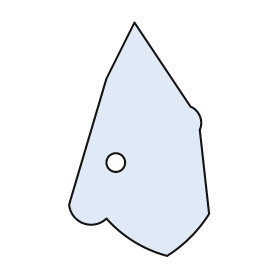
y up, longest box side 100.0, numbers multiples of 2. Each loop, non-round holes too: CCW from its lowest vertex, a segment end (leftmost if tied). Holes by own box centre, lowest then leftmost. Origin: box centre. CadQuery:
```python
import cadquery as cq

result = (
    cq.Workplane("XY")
    .moveTo(12.0, -50.0)
    .threePointArc((22.0, -42.0), (30.0, -32.0))
    .lineTo(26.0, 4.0)
    .threePointArc((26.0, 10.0), (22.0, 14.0))
    .lineTo(-2.0, 50.0)
    .lineTo(-14.0, 26.0)
    .lineTo(-30.0, -28.0)
    .threePointArc((-24.0, -36.0), (-14.0, -34.0))
    .threePointArc((-2.0, -44.0), (12.0, -50.0))
    .close()
    .moveTo(-10.0, -10.0)
    .circle(4.0)
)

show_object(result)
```